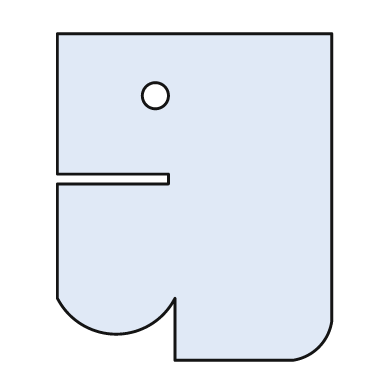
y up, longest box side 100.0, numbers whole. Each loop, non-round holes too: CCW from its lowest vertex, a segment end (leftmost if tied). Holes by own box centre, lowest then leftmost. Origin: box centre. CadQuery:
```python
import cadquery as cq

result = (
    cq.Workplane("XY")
    .moveTo(-6.0, -50.0)
    .lineTo(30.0, -50.0)
    .threePointArc((38.0, -46.0), (42.0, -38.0))
    .lineTo(42.0, 50.0)
    .lineTo(-42.0, 50.0)
    .lineTo(-42.0, 7.0)
    .lineTo(-8.0, 7.0)
    .lineTo(-8.0, 4.0)
    .lineTo(-42.0, 4.0)
    .lineTo(-42.0, -31.0)
    .threePointArc((-24.0, -42.0), (-6.0, -31.0))
    .close()
    .moveTo(-12.0, 31.0)
    .circle(4.0)
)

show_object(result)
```